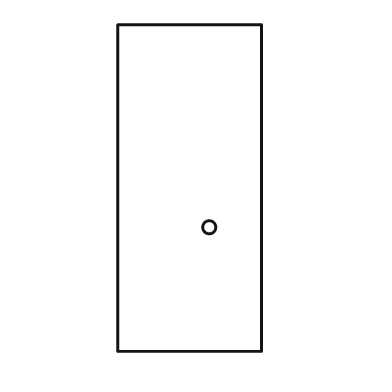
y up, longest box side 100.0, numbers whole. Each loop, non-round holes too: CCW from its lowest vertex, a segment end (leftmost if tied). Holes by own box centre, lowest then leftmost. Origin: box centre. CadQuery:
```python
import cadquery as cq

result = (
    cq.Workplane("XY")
    .moveTo(-22.0, -50.0)
    .lineTo(22.0, -50.0)
    .lineTo(22.0, 50.0)
    .lineTo(-22.0, 50.0)
    .close()
    .moveTo(6.0, -12.0)
    .circle(2.0)
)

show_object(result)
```